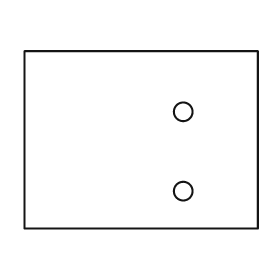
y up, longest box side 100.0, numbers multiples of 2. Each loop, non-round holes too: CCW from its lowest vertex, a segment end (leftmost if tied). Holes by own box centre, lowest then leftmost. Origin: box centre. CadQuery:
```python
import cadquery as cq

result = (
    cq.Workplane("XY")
    .moveTo(-50.0, -38.0)
    .lineTo(50.0, -38.0)
    .lineTo(50.0, 38.0)
    .lineTo(-50.0, 38.0)
    .close()
    .moveTo(18.0, -22.0)
    .circle(4.0)
    .moveTo(18.0, 12.0)
    .circle(4.0)
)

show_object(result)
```